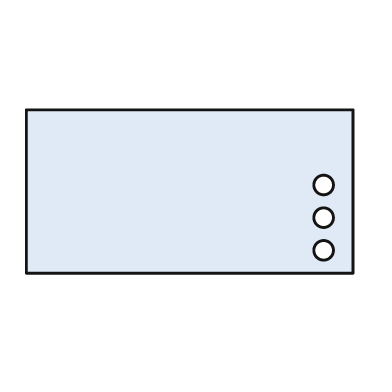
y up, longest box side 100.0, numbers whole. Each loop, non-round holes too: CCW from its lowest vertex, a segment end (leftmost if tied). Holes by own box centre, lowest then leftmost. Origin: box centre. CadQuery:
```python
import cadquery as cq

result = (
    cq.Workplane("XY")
    .moveTo(-50.0, -25.0)
    .lineTo(50.0, -25.0)
    .lineTo(50.0, 25.0)
    .lineTo(-50.0, 25.0)
    .close()
    .moveTo(41.0, -18.0)
    .circle(3.0)
    .moveTo(41.0, -8.0)
    .circle(3.0)
    .moveTo(41.0, 2.0)
    .circle(3.0)
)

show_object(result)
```